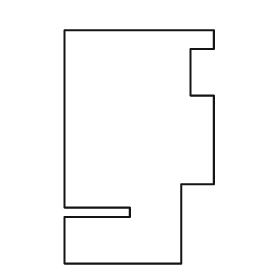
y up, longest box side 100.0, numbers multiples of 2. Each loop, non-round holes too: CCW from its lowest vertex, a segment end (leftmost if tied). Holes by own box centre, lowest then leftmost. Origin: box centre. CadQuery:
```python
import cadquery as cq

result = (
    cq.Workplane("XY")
    .moveTo(-32.0, -50.0)
    .lineTo(18.0, -50.0)
    .lineTo(18.0, -16.0)
    .lineTo(32.0, -16.0)
    .lineTo(32.0, 22.0)
    .lineTo(22.0, 22.0)
    .lineTo(22.0, 42.0)
    .lineTo(32.0, 42.0)
    .lineTo(32.0, 50.0)
    .lineTo(-32.0, 50.0)
    .lineTo(-32.0, -26.0)
    .lineTo(-4.0, -26.0)
    .lineTo(-4.0, -30.0)
    .lineTo(-32.0, -30.0)
    .close()
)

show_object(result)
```